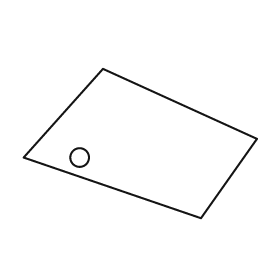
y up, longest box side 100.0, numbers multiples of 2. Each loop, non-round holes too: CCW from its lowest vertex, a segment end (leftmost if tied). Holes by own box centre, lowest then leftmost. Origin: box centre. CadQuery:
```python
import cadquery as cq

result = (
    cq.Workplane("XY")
    .moveTo(26.0, -32.0)
    .lineTo(50.0, 2.0)
    .lineTo(-16.0, 32.0)
    .lineTo(-50.0, -6.0)
    .close()
    .moveTo(-26.0, -6.0)
    .circle(4.0)
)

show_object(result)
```